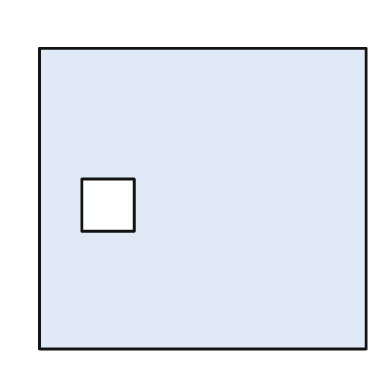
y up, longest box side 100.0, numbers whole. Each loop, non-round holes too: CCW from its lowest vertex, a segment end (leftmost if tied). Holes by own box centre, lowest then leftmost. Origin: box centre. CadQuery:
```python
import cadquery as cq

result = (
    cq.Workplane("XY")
    .moveTo(-50.0, -46.0)
    .lineTo(50.0, -46.0)
    .lineTo(50.0, 46.0)
    .lineTo(-50.0, 46.0)
    .close()
    .moveTo(-37.0, -10.0)
    .lineTo(-21.0, -10.0)
    .lineTo(-21.0, 6.0)
    .lineTo(-37.0, 6.0)
    .close()
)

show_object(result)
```